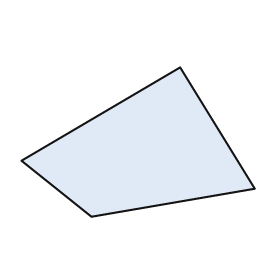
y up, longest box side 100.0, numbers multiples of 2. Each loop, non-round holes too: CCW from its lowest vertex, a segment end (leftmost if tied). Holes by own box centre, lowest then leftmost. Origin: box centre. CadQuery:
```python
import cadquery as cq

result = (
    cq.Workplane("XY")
    .moveTo(-20.0, -32.0)
    .lineTo(50.0, -20.0)
    .lineTo(18.0, 32.0)
    .lineTo(-50.0, -8.0)
    .close()
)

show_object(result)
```